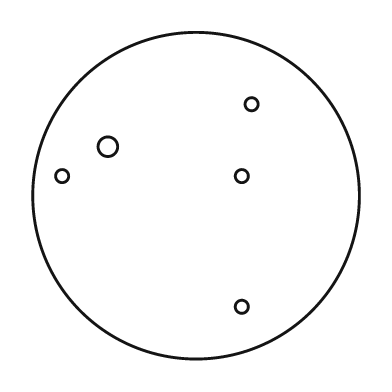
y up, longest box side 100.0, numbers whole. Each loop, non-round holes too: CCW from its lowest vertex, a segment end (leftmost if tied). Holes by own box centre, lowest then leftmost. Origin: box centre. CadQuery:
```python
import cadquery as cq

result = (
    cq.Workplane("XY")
    .moveTo(0.0, 0.0)
    .circle(50.0)
    .moveTo(14.0, -34.0)
    .circle(2.0)
    .moveTo(-41.0, 6.0)
    .circle(2.0)
    .moveTo(14.0, 6.0)
    .circle(2.0)
    .moveTo(-27.0, 15.0)
    .circle(3.0)
    .moveTo(17.0, 28.0)
    .circle(2.0)
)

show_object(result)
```